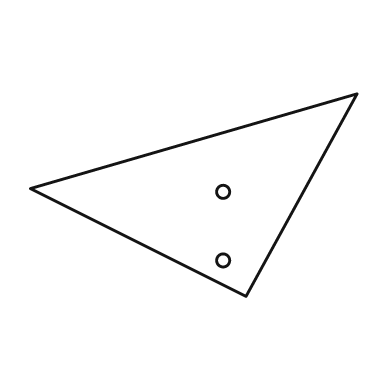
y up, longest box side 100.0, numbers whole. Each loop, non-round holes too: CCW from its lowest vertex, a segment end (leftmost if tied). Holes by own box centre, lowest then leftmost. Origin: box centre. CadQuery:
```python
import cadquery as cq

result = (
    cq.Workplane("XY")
    .moveTo(16.0, -31.0)
    .lineTo(50.0, 31.0)
    .lineTo(-50.0, 2.0)
    .close()
    .moveTo(9.0, -20.0)
    .circle(2.0)
    .moveTo(9.0, 1.0)
    .circle(2.0)
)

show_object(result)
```